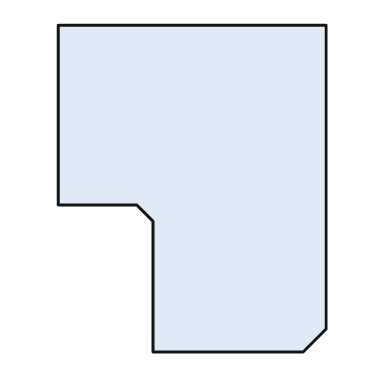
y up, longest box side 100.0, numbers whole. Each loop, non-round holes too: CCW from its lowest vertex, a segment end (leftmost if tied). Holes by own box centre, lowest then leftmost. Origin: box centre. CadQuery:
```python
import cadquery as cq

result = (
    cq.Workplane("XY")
    .moveTo(-12.0, -50.0)
    .lineTo(34.0, -50.0)
    .lineTo(41.0, -43.0)
    .lineTo(41.0, 50.0)
    .lineTo(-41.0, 50.0)
    .lineTo(-41.0, -5.0)
    .lineTo(-17.0, -5.0)
    .lineTo(-12.0, -10.0)
    .close()
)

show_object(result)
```